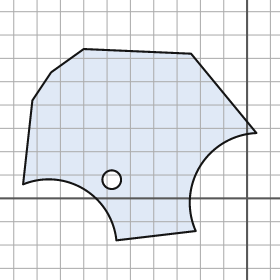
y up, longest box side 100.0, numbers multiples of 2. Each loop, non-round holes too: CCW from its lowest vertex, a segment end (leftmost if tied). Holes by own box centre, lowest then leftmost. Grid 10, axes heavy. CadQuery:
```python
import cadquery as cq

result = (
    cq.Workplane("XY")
    .moveTo(-56.0, -18.0)
    .lineTo(-22.0, -14.0)
    .threePointArc((-20.0, 14.0), (4.0, 28.0))
    .lineTo(-24.0, 62.0)
    .lineTo(-70.0, 64.0)
    .lineTo(-84.0, 54.0)
    .lineTo(-92.0, 42.0)
    .lineTo(-96.0, 6.0)
    .threePointArc((-70.0, 4.0), (-56.0, -18.0))
    .close()
    .moveTo(-58.0, 8.0)
    .circle(4.0)
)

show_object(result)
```